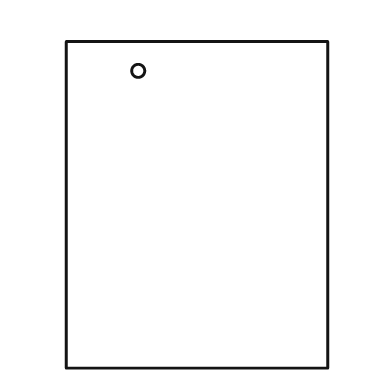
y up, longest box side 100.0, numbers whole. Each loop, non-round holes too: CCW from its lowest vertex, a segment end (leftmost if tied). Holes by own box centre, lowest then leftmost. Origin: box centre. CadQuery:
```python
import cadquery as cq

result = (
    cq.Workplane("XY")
    .moveTo(-40.0, -50.0)
    .lineTo(40.0, -50.0)
    .lineTo(40.0, 50.0)
    .lineTo(-40.0, 50.0)
    .close()
    .moveTo(-18.0, 41.0)
    .circle(2.0)
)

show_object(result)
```